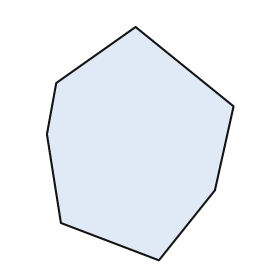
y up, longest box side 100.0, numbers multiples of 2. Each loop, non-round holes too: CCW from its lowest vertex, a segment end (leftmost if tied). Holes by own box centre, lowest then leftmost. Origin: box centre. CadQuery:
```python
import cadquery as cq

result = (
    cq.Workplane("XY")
    .moveTo(8.0, -50.0)
    .lineTo(32.0, -20.0)
    .lineTo(40.0, 16.0)
    .lineTo(-2.0, 50.0)
    .lineTo(-36.0, 26.0)
    .lineTo(-40.0, 4.0)
    .lineTo(-34.0, -34.0)
    .close()
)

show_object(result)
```